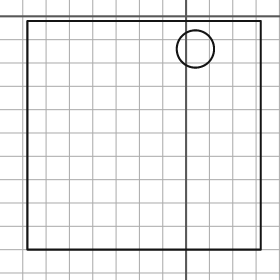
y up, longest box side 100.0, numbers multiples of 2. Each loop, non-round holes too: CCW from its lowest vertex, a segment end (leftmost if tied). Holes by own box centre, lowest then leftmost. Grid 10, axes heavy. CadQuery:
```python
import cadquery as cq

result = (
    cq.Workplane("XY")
    .moveTo(-68.0, -100.0)
    .lineTo(32.0, -100.0)
    .lineTo(32.0, -2.0)
    .lineTo(-68.0, -2.0)
    .close()
    .moveTo(4.0, -14.0)
    .circle(8.0)
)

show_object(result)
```